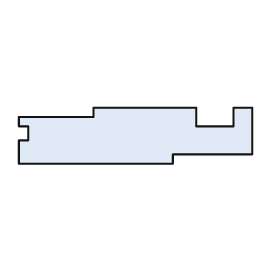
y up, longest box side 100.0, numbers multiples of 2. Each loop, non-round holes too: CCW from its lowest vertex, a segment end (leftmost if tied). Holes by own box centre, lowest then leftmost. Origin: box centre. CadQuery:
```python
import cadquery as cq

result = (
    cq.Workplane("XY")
    .moveTo(-50.0, -12.0)
    .lineTo(16.0, -12.0)
    .lineTo(16.0, -8.0)
    .lineTo(50.0, -8.0)
    .lineTo(50.0, 12.0)
    .lineTo(42.0, 12.0)
    .lineTo(42.0, 4.0)
    .lineTo(26.0, 4.0)
    .lineTo(26.0, 12.0)
    .lineTo(-18.0, 12.0)
    .lineTo(-18.0, 8.0)
    .lineTo(-50.0, 8.0)
    .lineTo(-50.0, 4.0)
    .lineTo(-46.0, 4.0)
    .lineTo(-46.0, -2.0)
    .lineTo(-50.0, -2.0)
    .close()
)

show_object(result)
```